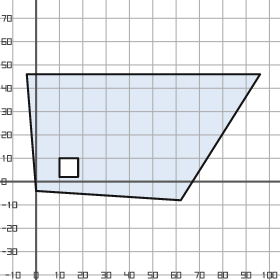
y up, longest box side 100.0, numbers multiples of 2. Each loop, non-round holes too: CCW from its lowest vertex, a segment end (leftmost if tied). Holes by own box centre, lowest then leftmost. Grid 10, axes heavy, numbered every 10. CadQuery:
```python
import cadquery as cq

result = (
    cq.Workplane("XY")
    .moveTo(62.0, -8.0)
    .lineTo(96.0, 46.0)
    .lineTo(-4.0, 46.0)
    .lineTo(0.0, -4.0)
    .close()
    .moveTo(10.0, 2.0)
    .lineTo(18.0, 2.0)
    .lineTo(18.0, 10.0)
    .lineTo(10.0, 10.0)
    .close()
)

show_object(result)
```